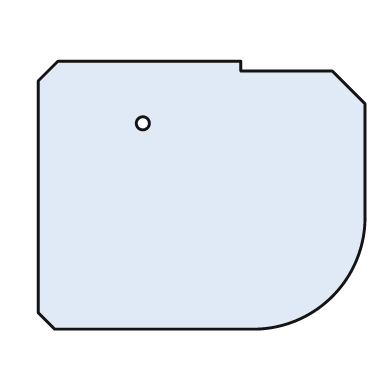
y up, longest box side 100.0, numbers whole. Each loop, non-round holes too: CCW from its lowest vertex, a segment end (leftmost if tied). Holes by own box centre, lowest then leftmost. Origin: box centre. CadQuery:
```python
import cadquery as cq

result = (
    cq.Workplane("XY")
    .moveTo(-45.0, -41.0)
    .lineTo(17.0, -41.0)
    .threePointArc((40.0, -31.0), (50.0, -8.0))
    .lineTo(50.0, 28.0)
    .lineTo(40.0, 38.0)
    .lineTo(12.0, 38.0)
    .lineTo(12.0, 41.0)
    .lineTo(-44.0, 41.0)
    .lineTo(-50.0, 35.0)
    .lineTo(-50.0, -36.0)
    .close()
    .moveTo(-18.0, 22.0)
    .circle(2.0)
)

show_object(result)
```